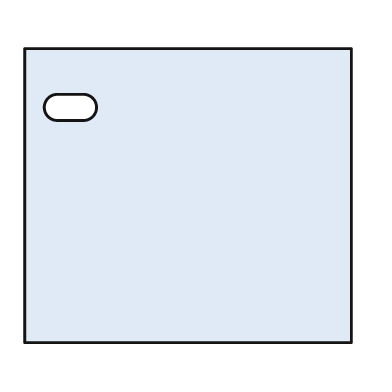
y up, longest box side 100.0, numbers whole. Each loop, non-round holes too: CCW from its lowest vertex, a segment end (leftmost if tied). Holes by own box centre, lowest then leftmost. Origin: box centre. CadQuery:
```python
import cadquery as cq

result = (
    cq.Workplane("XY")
    .moveTo(-50.0, -45.0)
    .lineTo(50.0, -45.0)
    .lineTo(50.0, 45.0)
    .lineTo(-50.0, 45.0)
    .close()
    .moveTo(-40.0, 23.0)
    .lineTo(-32.0, 23.0)
    .threePointArc((-28.0, 27.0), (-32.0, 31.0))
    .lineTo(-40.0, 31.0)
    .threePointArc((-44.0, 27.0), (-40.0, 23.0))
    .close()
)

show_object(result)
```